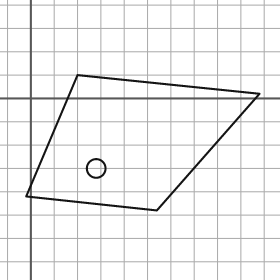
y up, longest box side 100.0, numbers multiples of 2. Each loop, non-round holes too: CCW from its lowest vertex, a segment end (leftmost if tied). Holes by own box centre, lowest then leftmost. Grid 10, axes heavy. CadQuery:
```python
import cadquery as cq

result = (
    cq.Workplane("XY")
    .moveTo(54.0, -48.0)
    .lineTo(98.0, 2.0)
    .lineTo(20.0, 10.0)
    .lineTo(-2.0, -42.0)
    .close()
    .moveTo(28.0, -30.0)
    .circle(4.0)
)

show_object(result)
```